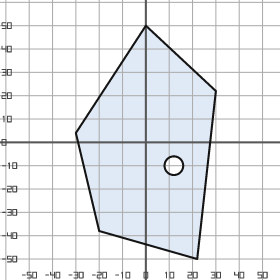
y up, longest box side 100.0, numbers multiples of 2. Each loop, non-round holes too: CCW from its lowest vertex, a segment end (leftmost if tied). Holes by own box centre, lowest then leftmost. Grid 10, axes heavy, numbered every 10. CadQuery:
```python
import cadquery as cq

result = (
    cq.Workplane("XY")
    .moveTo(22.0, -50.0)
    .lineTo(30.0, 22.0)
    .lineTo(0.0, 50.0)
    .lineTo(-30.0, 4.0)
    .lineTo(-20.0, -38.0)
    .close()
    .moveTo(12.0, -10.0)
    .circle(4.0)
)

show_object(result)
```